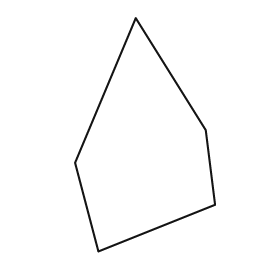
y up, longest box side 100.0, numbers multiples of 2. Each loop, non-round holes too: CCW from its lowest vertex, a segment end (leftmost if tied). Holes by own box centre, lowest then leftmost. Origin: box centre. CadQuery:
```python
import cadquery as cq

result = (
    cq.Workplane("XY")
    .moveTo(-20.0, -50.0)
    .lineTo(30.0, -30.0)
    .lineTo(26.0, 2.0)
    .lineTo(-4.0, 50.0)
    .lineTo(-30.0, -12.0)
    .close()
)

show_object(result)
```